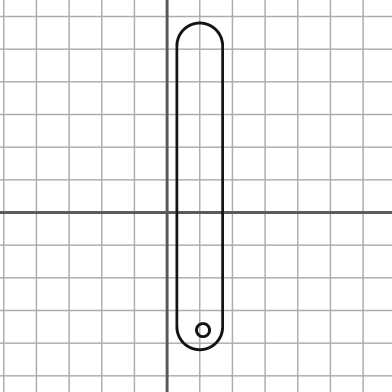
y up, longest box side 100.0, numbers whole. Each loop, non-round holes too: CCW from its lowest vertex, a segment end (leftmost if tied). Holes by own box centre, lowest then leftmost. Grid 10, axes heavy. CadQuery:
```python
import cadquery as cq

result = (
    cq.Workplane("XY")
    .moveTo(3.0, -35.0)
    .threePointArc((10.0, -42.0), (17.0, -35.0))
    .lineTo(17.0, 51.0)
    .threePointArc((10.0, 58.0), (3.0, 51.0))
    .close()
    .moveTo(11.0, -36.0)
    .circle(2.0)
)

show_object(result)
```